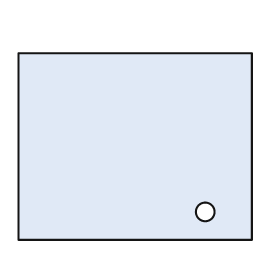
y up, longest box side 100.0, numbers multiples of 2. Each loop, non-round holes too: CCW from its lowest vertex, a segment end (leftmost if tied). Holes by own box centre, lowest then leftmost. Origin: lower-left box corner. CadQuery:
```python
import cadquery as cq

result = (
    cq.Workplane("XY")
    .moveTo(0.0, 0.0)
    .lineTo(100.0, 0.0)
    .lineTo(100.0, 80.0)
    .lineTo(0.0, 80.0)
    .close()
    .moveTo(80.0, 12.0)
    .circle(4.0)
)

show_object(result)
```